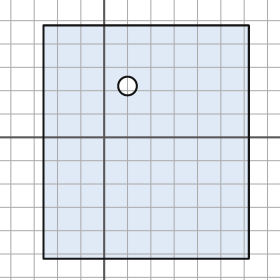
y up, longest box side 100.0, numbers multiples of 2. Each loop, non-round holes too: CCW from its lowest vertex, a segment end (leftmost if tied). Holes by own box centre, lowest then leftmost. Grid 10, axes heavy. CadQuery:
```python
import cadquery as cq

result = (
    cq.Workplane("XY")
    .moveTo(-26.0, -52.0)
    .lineTo(62.0, -52.0)
    .lineTo(62.0, 48.0)
    .lineTo(-26.0, 48.0)
    .close()
    .moveTo(10.0, 22.0)
    .circle(4.0)
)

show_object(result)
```